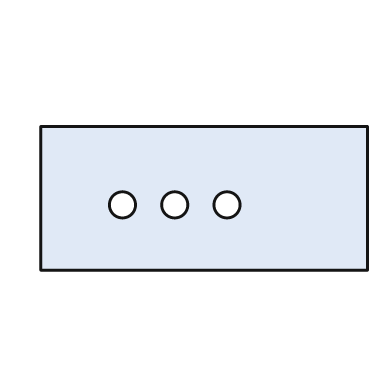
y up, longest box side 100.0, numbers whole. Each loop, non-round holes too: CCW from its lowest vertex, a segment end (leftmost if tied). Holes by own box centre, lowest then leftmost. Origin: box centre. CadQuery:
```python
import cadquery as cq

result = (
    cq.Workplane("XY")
    .moveTo(-50.0, -22.0)
    .lineTo(50.0, -22.0)
    .lineTo(50.0, 22.0)
    .lineTo(-50.0, 22.0)
    .close()
    .moveTo(-25.0, -2.0)
    .circle(4.0)
    .moveTo(-9.0, -2.0)
    .circle(4.0)
    .moveTo(7.0, -2.0)
    .circle(4.0)
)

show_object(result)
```